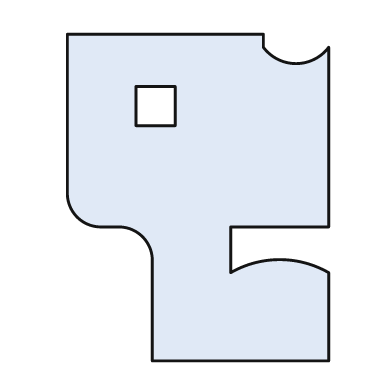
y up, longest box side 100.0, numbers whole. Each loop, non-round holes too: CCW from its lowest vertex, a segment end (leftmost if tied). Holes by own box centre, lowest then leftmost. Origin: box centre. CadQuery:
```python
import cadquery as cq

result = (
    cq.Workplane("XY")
    .moveTo(-14.0, -50.0)
    .lineTo(40.0, -50.0)
    .lineTo(40.0, -23.0)
    .threePointArc((25.0, -19.0), (10.0, -23.0))
    .lineTo(10.0, -9.0)
    .lineTo(40.0, -9.0)
    .lineTo(40.0, 46.0)
    .threePointArc((30.0, 41.0), (20.0, 46.0))
    .lineTo(20.0, 50.0)
    .lineTo(-40.0, 50.0)
    .lineTo(-40.0, 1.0)
    .threePointArc((-37.0, -6.0), (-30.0, -9.0))
    .lineTo(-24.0, -9.0)
    .threePointArc((-17.0, -12.0), (-14.0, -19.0))
    .close()
    .moveTo(-19.0, 22.0)
    .lineTo(-7.0, 22.0)
    .lineTo(-7.0, 34.0)
    .lineTo(-19.0, 34.0)
    .close()
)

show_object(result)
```